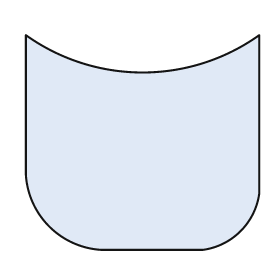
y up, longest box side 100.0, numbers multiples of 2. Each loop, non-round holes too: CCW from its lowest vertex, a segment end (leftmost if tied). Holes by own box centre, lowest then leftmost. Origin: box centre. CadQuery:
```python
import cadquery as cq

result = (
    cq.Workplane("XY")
    .moveTo(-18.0, -46.0)
    .lineTo(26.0, -46.0)
    .threePointArc((42.0, -38.0), (50.0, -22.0))
    .lineTo(50.0, 46.0)
    .threePointArc((0.0, 30.0), (-50.0, 46.0))
    .lineTo(-50.0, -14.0)
    .threePointArc((-40.0, -36.0), (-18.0, -46.0))
    .close()
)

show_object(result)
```